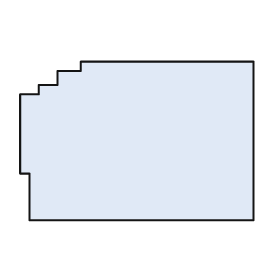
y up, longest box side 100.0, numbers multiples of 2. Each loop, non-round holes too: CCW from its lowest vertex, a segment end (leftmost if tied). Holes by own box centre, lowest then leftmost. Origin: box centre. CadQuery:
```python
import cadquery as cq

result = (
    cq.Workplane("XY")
    .moveTo(-46.0, -34.0)
    .lineTo(50.0, -34.0)
    .lineTo(50.0, 34.0)
    .lineTo(-24.0, 34.0)
    .lineTo(-24.0, 30.0)
    .lineTo(-34.0, 30.0)
    .lineTo(-34.0, 24.0)
    .lineTo(-42.0, 24.0)
    .lineTo(-42.0, 20.0)
    .lineTo(-50.0, 20.0)
    .lineTo(-50.0, -14.0)
    .lineTo(-46.0, -14.0)
    .close()
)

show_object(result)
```